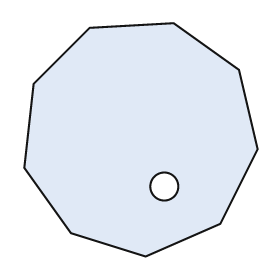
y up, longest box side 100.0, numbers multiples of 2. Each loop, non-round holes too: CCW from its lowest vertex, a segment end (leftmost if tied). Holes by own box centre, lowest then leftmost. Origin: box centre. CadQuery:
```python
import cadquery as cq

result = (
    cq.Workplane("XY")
    .moveTo(2.0, -50.0)
    .lineTo(34.0, -36.0)
    .lineTo(50.0, -4.0)
    .lineTo(42.0, 30.0)
    .lineTo(14.0, 50.0)
    .lineTo(-22.0, 48.0)
    .lineTo(-46.0, 24.0)
    .lineTo(-50.0, -12.0)
    .lineTo(-30.0, -40.0)
    .close()
    .moveTo(10.0, -20.0)
    .circle(6.0)
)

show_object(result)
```